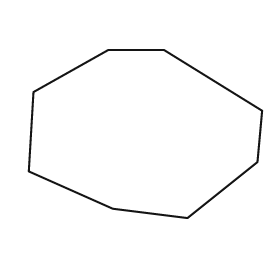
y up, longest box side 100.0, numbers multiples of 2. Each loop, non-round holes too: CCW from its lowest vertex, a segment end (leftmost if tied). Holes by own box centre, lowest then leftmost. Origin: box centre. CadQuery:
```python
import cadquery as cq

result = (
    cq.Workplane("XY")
    .moveTo(18.0, -36.0)
    .lineTo(48.0, -12.0)
    .lineTo(50.0, 10.0)
    .lineTo(8.0, 36.0)
    .lineTo(-16.0, 36.0)
    .lineTo(-48.0, 18.0)
    .lineTo(-50.0, -16.0)
    .lineTo(-14.0, -32.0)
    .close()
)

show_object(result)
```